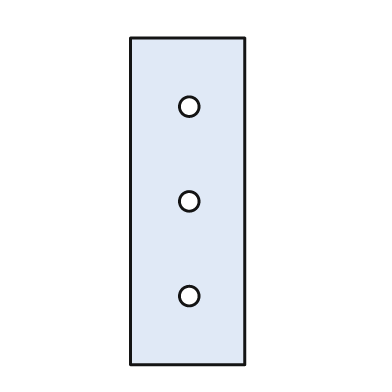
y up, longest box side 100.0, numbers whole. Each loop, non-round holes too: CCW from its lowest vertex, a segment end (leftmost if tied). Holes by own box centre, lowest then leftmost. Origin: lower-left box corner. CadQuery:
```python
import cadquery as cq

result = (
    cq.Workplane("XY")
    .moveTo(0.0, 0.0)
    .lineTo(35.0, 0.0)
    .lineTo(35.0, 100.0)
    .lineTo(0.0, 100.0)
    .close()
    .moveTo(18.0, 21.0)
    .circle(3.0)
    .moveTo(18.0, 50.0)
    .circle(3.0)
    .moveTo(18.0, 79.0)
    .circle(3.0)
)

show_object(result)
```